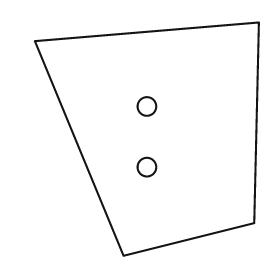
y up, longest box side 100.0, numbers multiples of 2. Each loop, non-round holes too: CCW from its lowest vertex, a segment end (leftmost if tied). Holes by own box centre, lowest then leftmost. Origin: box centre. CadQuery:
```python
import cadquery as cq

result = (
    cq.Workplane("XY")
    .moveTo(-10.0, -50.0)
    .lineTo(46.0, -36.0)
    .lineTo(48.0, 50.0)
    .lineTo(-48.0, 42.0)
    .close()
    .moveTo(0.0, -12.0)
    .circle(4.0)
    .moveTo(0.0, 14.0)
    .circle(4.0)
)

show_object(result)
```